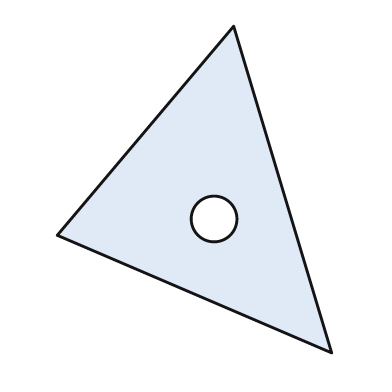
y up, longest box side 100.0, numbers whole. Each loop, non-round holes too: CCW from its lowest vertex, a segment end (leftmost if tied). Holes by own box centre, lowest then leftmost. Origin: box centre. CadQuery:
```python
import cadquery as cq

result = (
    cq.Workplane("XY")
    .moveTo(42.0, -50.0)
    .lineTo(12.0, 50.0)
    .lineTo(-42.0, -14.0)
    .close()
    .moveTo(6.0, -9.0)
    .circle(7.0)
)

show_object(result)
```